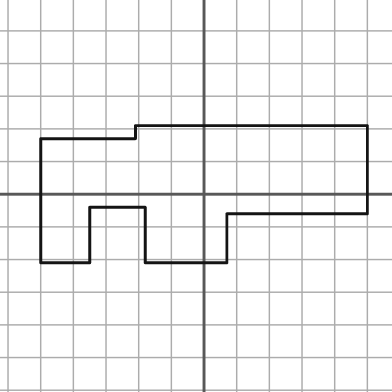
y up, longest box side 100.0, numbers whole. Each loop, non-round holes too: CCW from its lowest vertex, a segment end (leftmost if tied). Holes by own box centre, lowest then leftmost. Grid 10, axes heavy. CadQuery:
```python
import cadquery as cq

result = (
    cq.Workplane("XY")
    .moveTo(-50.0, -21.0)
    .lineTo(-35.0, -21.0)
    .lineTo(-35.0, -4.0)
    .lineTo(-18.0, -4.0)
    .lineTo(-18.0, -21.0)
    .lineTo(7.0, -21.0)
    .lineTo(7.0, -6.0)
    .lineTo(50.0, -6.0)
    .lineTo(50.0, 21.0)
    .lineTo(-21.0, 21.0)
    .lineTo(-21.0, 17.0)
    .lineTo(-50.0, 17.0)
    .close()
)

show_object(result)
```